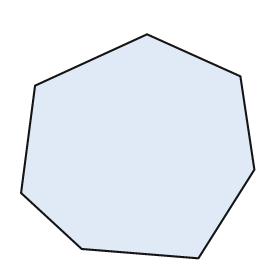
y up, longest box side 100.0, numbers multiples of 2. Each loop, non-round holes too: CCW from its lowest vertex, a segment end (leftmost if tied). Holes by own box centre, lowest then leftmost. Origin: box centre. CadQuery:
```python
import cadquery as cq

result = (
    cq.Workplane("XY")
    .moveTo(26.0, -48.0)
    .lineTo(50.0, -10.0)
    .lineTo(44.0, 30.0)
    .lineTo(4.0, 48.0)
    .lineTo(-44.0, 26.0)
    .lineTo(-50.0, -20.0)
    .lineTo(-24.0, -44.0)
    .close()
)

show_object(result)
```